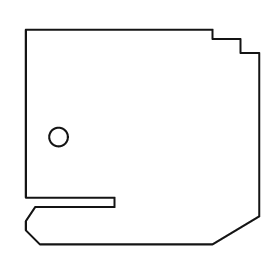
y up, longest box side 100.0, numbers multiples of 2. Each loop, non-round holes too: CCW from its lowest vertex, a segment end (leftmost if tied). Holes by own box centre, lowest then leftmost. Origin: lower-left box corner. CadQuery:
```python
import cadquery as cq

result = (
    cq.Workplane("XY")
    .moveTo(6.0, 0.0)
    .lineTo(80.0, 0.0)
    .lineTo(100.0, 12.0)
    .lineTo(100.0, 82.0)
    .lineTo(92.0, 82.0)
    .lineTo(92.0, 88.0)
    .lineTo(80.0, 88.0)
    .lineTo(80.0, 92.0)
    .lineTo(0.0, 92.0)
    .lineTo(0.0, 20.0)
    .lineTo(38.0, 20.0)
    .lineTo(38.0, 16.0)
    .lineTo(4.0, 16.0)
    .lineTo(0.0, 10.0)
    .lineTo(0.0, 6.0)
    .close()
    .moveTo(14.0, 46.0)
    .circle(4.0)
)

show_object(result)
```